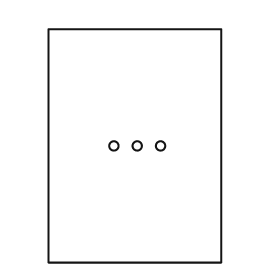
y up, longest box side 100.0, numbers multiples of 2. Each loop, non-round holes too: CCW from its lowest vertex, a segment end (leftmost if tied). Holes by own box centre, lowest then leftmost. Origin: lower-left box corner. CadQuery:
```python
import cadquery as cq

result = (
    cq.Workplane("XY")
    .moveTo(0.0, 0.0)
    .lineTo(74.0, 0.0)
    .lineTo(74.0, 100.0)
    .lineTo(0.0, 100.0)
    .close()
    .moveTo(28.0, 50.0)
    .circle(2.0)
    .moveTo(38.0, 50.0)
    .circle(2.0)
    .moveTo(48.0, 50.0)
    .circle(2.0)
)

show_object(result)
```